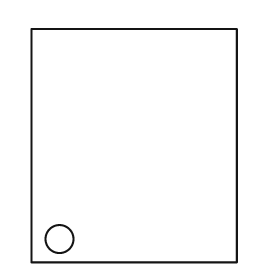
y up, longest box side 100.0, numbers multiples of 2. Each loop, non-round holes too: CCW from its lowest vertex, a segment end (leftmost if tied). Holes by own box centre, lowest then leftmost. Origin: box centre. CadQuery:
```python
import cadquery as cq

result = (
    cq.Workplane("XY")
    .moveTo(-44.0, -50.0)
    .lineTo(44.0, -50.0)
    .lineTo(44.0, 50.0)
    .lineTo(-44.0, 50.0)
    .close()
    .moveTo(-32.0, -40.0)
    .circle(6.0)
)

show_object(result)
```